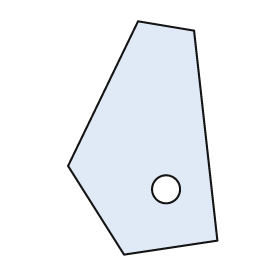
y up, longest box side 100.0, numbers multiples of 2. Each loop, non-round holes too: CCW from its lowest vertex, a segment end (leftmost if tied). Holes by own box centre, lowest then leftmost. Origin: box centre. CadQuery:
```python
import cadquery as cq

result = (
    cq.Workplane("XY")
    .moveTo(-8.0, -50.0)
    .lineTo(32.0, -44.0)
    .lineTo(22.0, 46.0)
    .lineTo(-2.0, 50.0)
    .lineTo(-32.0, -12.0)
    .close()
    .moveTo(10.0, -22.0)
    .circle(6.0)
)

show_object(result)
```